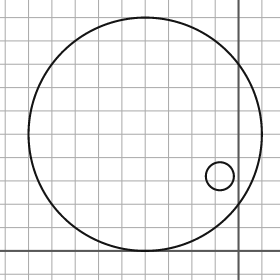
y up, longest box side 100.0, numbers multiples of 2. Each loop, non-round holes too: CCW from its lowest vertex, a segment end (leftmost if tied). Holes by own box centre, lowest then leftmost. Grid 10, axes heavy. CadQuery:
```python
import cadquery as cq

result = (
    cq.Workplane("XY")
    .moveTo(-40.0, 50.0)
    .circle(50.0)
    .moveTo(-8.0, 32.0)
    .circle(6.0)
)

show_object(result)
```